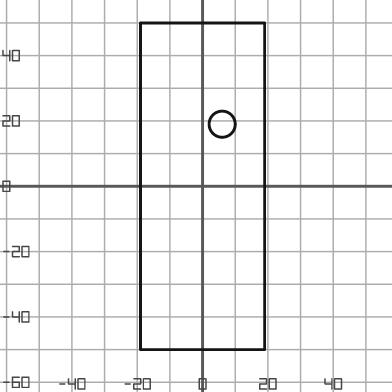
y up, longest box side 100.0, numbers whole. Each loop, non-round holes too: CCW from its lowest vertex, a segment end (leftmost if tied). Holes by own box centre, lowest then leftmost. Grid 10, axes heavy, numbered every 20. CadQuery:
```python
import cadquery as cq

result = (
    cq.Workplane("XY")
    .moveTo(-19.0, -50.0)
    .lineTo(19.0, -50.0)
    .lineTo(19.0, 50.0)
    .lineTo(-19.0, 50.0)
    .close()
    .moveTo(6.0, 19.0)
    .circle(4.0)
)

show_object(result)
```